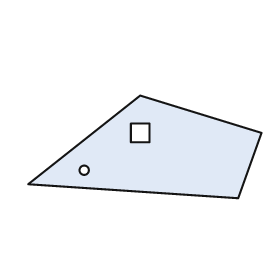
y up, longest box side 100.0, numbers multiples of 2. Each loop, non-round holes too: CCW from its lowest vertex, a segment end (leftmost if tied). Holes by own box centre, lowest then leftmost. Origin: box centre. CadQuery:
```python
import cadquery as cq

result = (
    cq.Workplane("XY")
    .moveTo(40.0, -22.0)
    .lineTo(50.0, 6.0)
    .lineTo(-2.0, 22.0)
    .lineTo(-50.0, -16.0)
    .close()
    .moveTo(-26.0, -10.0)
    .circle(2.0)
    .moveTo(-6.0, 2.0)
    .lineTo(2.0, 2.0)
    .lineTo(2.0, 10.0)
    .lineTo(-6.0, 10.0)
    .close()
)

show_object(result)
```